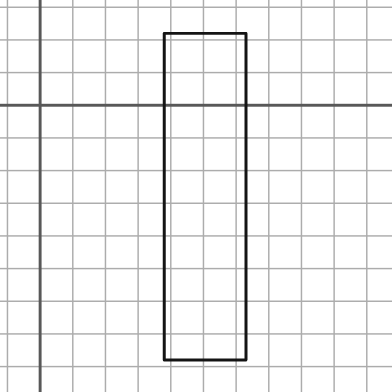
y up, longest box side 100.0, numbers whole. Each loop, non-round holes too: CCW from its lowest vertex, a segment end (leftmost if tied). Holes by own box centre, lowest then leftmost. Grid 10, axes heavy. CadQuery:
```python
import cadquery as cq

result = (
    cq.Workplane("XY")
    .moveTo(38.0, -78.0)
    .lineTo(63.0, -78.0)
    .lineTo(63.0, 22.0)
    .lineTo(38.0, 22.0)
    .close()
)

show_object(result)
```